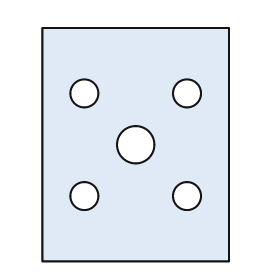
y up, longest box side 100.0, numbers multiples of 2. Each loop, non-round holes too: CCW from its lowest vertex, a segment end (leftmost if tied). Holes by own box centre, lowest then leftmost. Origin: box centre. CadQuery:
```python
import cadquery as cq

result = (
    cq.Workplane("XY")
    .moveTo(-40.0, -50.0)
    .lineTo(40.0, -50.0)
    .lineTo(40.0, 50.0)
    .lineTo(-40.0, 50.0)
    .close()
    .moveTo(-22.0, -22.0)
    .circle(6.0)
    .moveTo(22.0, -22.0)
    .circle(6.0)
    .moveTo(0.0, 0.0)
    .circle(8.0)
    .moveTo(-22.0, 22.0)
    .circle(6.0)
    .moveTo(22.0, 22.0)
    .circle(6.0)
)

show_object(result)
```